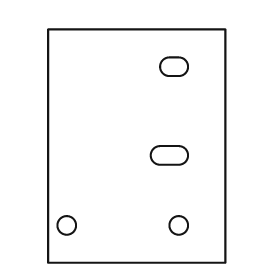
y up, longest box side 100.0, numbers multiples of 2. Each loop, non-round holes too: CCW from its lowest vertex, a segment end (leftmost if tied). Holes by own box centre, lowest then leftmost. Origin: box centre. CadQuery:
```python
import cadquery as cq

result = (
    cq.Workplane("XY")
    .moveTo(-38.0, -50.0)
    .lineTo(38.0, -50.0)
    .lineTo(38.0, 50.0)
    .lineTo(-38.0, 50.0)
    .close()
    .moveTo(-30.0, -34.0)
    .circle(4.0)
    .moveTo(18.0, -34.0)
    .circle(4.0)
    .moveTo(10.0, -8.0)
    .lineTo(18.0, -8.0)
    .threePointArc((22.0, -4.0), (18.0, 0.0))
    .lineTo(10.0, 0.0)
    .threePointArc((6.0, -4.0), (10.0, -8.0))
    .close()
    .moveTo(14.0, 30.0)
    .lineTo(18.0, 30.0)
    .threePointArc((22.0, 34.0), (18.0, 38.0))
    .lineTo(14.0, 38.0)
    .threePointArc((10.0, 34.0), (14.0, 30.0))
    .close()
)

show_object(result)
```